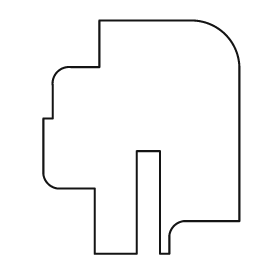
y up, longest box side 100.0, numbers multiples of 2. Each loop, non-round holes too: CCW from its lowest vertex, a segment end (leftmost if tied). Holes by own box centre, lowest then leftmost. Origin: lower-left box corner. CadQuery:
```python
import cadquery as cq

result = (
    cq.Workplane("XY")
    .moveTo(22.0, 0.0)
    .lineTo(40.0, 0.0)
    .lineTo(40.0, 44.0)
    .lineTo(50.0, 44.0)
    .lineTo(50.0, 0.0)
    .lineTo(54.0, 0.0)
    .lineTo(54.0, 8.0)
    .threePointArc((56.0, 12.0), (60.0, 14.0))
    .lineTo(84.0, 14.0)
    .lineTo(84.0, 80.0)
    .threePointArc((78.0, 94.0), (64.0, 100.0))
    .lineTo(24.0, 100.0)
    .lineTo(24.0, 80.0)
    .lineTo(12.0, 80.0)
    .threePointArc((6.0, 78.0), (4.0, 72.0))
    .lineTo(4.0, 58.0)
    .lineTo(0.0, 58.0)
    .lineTo(0.0, 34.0)
    .threePointArc((2.0, 30.0), (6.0, 28.0))
    .lineTo(22.0, 28.0)
    .close()
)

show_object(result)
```